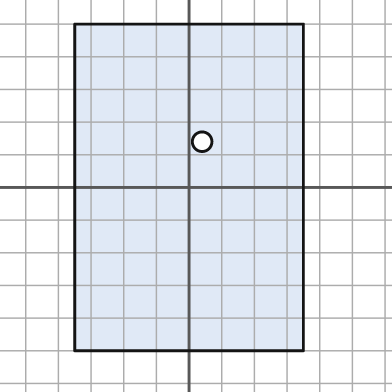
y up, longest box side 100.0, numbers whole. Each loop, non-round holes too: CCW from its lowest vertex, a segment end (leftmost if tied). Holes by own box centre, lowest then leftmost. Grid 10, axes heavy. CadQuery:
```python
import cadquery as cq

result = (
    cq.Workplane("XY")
    .moveTo(-35.0, -50.0)
    .lineTo(35.0, -50.0)
    .lineTo(35.0, 50.0)
    .lineTo(-35.0, 50.0)
    .close()
    .moveTo(4.0, 14.0)
    .circle(3.0)
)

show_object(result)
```